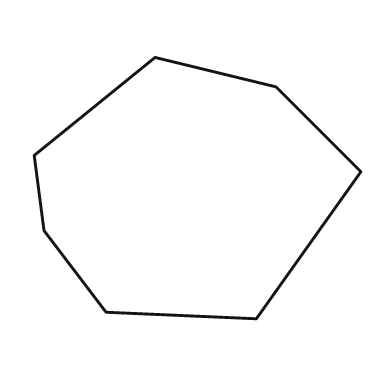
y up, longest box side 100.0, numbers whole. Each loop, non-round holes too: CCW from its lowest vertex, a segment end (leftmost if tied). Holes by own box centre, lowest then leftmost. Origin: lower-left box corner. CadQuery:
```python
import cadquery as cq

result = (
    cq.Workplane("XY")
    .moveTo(68.0, 0.0)
    .lineTo(100.0, 45.0)
    .lineTo(74.0, 71.0)
    .lineTo(37.0, 80.0)
    .lineTo(0.0, 50.0)
    .lineTo(3.0, 27.0)
    .lineTo(22.0, 2.0)
    .close()
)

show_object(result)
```